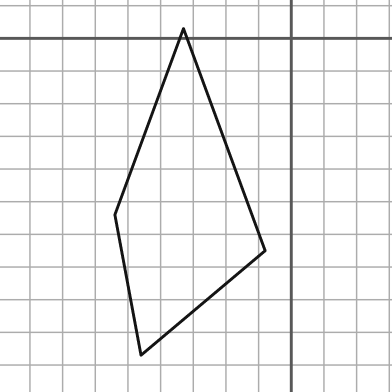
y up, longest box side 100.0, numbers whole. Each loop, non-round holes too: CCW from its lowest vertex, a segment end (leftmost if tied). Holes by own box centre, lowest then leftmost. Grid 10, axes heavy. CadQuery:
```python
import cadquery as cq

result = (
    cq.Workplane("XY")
    .moveTo(-46.0, -97.0)
    .lineTo(-8.0, -65.0)
    .lineTo(-33.0, 3.0)
    .lineTo(-54.0, -54.0)
    .close()
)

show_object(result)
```